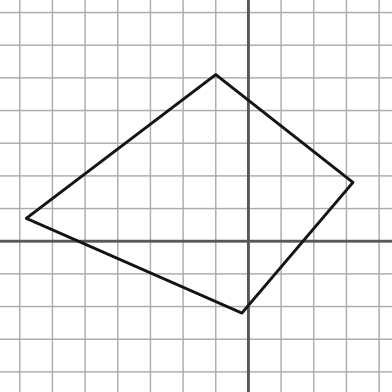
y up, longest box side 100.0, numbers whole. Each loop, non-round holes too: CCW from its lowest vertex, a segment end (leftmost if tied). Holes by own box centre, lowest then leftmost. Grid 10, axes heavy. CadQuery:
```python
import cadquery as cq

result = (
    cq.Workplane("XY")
    .moveTo(-2.0, -22.0)
    .lineTo(32.0, 18.0)
    .lineTo(-10.0, 51.0)
    .lineTo(-68.0, 7.0)
    .close()
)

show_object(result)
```